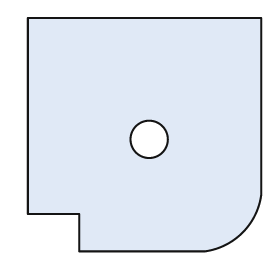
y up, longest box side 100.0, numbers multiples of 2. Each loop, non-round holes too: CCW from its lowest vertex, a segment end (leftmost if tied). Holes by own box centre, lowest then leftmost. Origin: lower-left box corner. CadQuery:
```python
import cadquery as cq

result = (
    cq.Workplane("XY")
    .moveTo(22.0, 0.0)
    .lineTo(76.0, 0.0)
    .threePointArc((92.0, 8.0), (100.0, 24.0))
    .lineTo(100.0, 100.0)
    .lineTo(0.0, 100.0)
    .lineTo(0.0, 16.0)
    .lineTo(22.0, 16.0)
    .close()
    .moveTo(52.0, 48.0)
    .circle(8.0)
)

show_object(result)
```